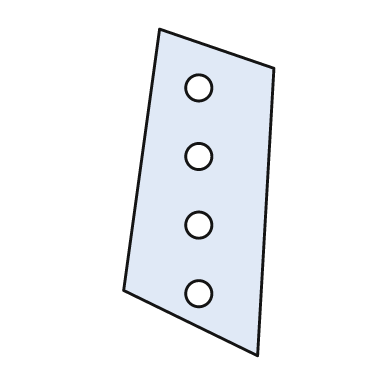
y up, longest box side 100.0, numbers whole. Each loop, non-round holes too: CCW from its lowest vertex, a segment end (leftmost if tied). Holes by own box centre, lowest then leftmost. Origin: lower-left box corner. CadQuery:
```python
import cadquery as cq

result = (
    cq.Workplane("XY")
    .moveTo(41.0, 0.0)
    .lineTo(46.0, 88.0)
    .lineTo(11.0, 100.0)
    .lineTo(0.0, 20.0)
    .close()
    .moveTo(23.0, 19.0)
    .circle(4.0)
    .moveTo(23.0, 40.0)
    .circle(4.0)
    .moveTo(23.0, 61.0)
    .circle(4.0)
    .moveTo(23.0, 82.0)
    .circle(4.0)
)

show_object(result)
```